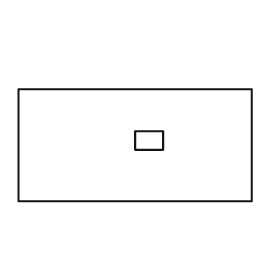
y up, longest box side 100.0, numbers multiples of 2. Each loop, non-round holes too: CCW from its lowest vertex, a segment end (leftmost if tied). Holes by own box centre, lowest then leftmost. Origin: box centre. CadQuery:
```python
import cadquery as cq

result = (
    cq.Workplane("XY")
    .moveTo(-50.0, -24.0)
    .lineTo(50.0, -24.0)
    .lineTo(50.0, 24.0)
    .lineTo(-50.0, 24.0)
    .close()
    .moveTo(0.0, -2.0)
    .lineTo(12.0, -2.0)
    .lineTo(12.0, 6.0)
    .lineTo(0.0, 6.0)
    .close()
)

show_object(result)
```